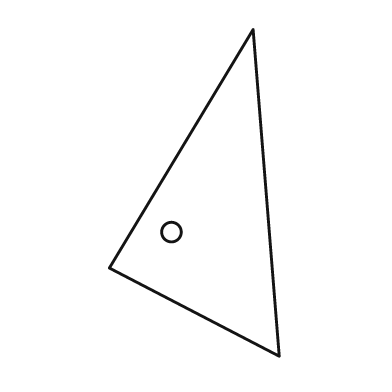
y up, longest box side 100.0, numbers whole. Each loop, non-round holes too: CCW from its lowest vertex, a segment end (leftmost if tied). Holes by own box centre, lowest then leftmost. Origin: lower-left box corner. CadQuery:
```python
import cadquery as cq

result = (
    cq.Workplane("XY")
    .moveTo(52.0, 0.0)
    .lineTo(44.0, 100.0)
    .lineTo(0.0, 27.0)
    .close()
    .moveTo(19.0, 38.0)
    .circle(3.0)
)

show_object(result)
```